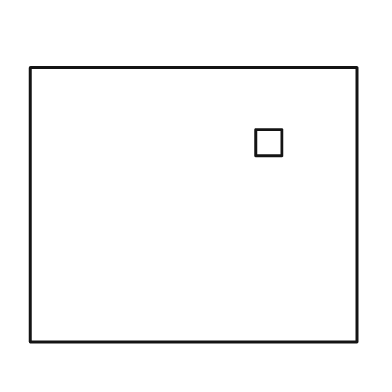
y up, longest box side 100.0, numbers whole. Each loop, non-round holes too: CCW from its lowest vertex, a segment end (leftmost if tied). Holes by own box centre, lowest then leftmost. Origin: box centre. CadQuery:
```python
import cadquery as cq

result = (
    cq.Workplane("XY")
    .moveTo(-50.0, -42.0)
    .lineTo(50.0, -42.0)
    .lineTo(50.0, 42.0)
    .lineTo(-50.0, 42.0)
    .close()
    .moveTo(19.0, 15.0)
    .lineTo(27.0, 15.0)
    .lineTo(27.0, 23.0)
    .lineTo(19.0, 23.0)
    .close()
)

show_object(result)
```